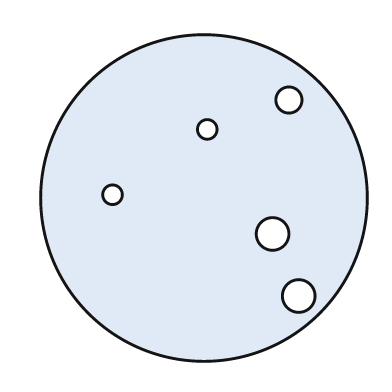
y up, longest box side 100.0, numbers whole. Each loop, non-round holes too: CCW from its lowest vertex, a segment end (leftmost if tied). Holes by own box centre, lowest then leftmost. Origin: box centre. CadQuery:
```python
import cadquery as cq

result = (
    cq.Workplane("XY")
    .moveTo(0.0, 0.0)
    .circle(50.0)
    .moveTo(29.0, -30.0)
    .circle(5.0)
    .moveTo(21.0, -11.0)
    .circle(5.0)
    .moveTo(-28.0, 1.0)
    .circle(3.0)
    .moveTo(1.0, 21.0)
    .circle(3.0)
    .moveTo(26.0, 30.0)
    .circle(4.0)
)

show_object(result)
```